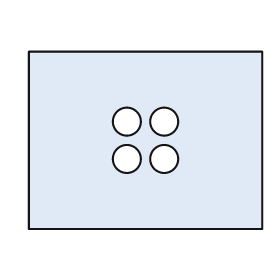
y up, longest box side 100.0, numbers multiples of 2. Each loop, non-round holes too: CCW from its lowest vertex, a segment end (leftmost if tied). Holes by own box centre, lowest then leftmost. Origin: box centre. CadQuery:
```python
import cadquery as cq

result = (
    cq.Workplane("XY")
    .moveTo(-50.0, -38.0)
    .lineTo(50.0, -38.0)
    .lineTo(50.0, 38.0)
    .lineTo(-50.0, 38.0)
    .close()
    .moveTo(-8.0, -8.0)
    .circle(6.0)
    .moveTo(8.0, -8.0)
    .circle(6.0)
    .moveTo(-8.0, 8.0)
    .circle(6.0)
    .moveTo(8.0, 8.0)
    .circle(6.0)
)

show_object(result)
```